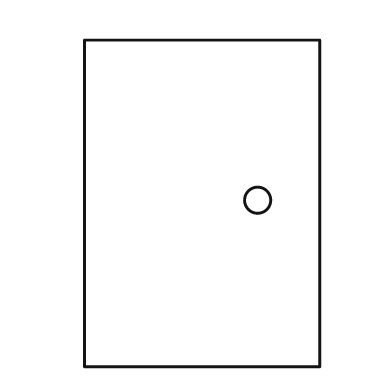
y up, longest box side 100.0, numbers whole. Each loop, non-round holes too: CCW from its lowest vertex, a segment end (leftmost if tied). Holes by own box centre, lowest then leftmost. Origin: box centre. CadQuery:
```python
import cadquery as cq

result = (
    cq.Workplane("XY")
    .moveTo(-36.0, -50.0)
    .lineTo(36.0, -50.0)
    .lineTo(36.0, 50.0)
    .lineTo(-36.0, 50.0)
    .close()
    .moveTo(17.0, 1.0)
    .circle(4.0)
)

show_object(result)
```